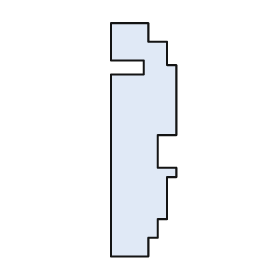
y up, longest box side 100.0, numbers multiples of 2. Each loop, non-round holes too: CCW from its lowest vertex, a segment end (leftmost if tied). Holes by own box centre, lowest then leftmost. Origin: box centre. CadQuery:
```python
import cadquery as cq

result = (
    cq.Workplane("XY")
    .moveTo(-14.0, -50.0)
    .lineTo(2.0, -50.0)
    .lineTo(2.0, -42.0)
    .lineTo(6.0, -42.0)
    .lineTo(6.0, -34.0)
    .lineTo(10.0, -34.0)
    .lineTo(10.0, -16.0)
    .lineTo(14.0, -16.0)
    .lineTo(14.0, -12.0)
    .lineTo(6.0, -12.0)
    .lineTo(6.0, 2.0)
    .lineTo(14.0, 2.0)
    .lineTo(14.0, 32.0)
    .lineTo(10.0, 32.0)
    .lineTo(10.0, 42.0)
    .lineTo(2.0, 42.0)
    .lineTo(2.0, 50.0)
    .lineTo(-14.0, 50.0)
    .lineTo(-14.0, 34.0)
    .lineTo(0.0, 34.0)
    .lineTo(0.0, 28.0)
    .lineTo(-14.0, 28.0)
    .close()
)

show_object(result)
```